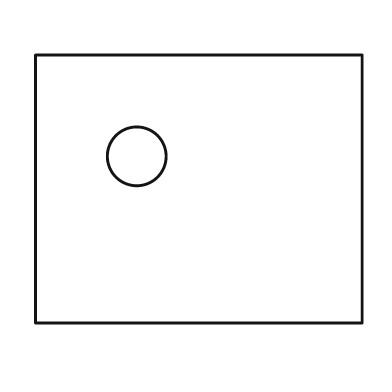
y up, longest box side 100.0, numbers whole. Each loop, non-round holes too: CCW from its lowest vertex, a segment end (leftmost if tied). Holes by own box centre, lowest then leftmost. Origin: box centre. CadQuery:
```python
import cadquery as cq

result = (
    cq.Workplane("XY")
    .moveTo(-50.0, -41.0)
    .lineTo(50.0, -41.0)
    .lineTo(50.0, 41.0)
    .lineTo(-50.0, 41.0)
    .close()
    .moveTo(-19.0, 10.0)
    .circle(9.0)
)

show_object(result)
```